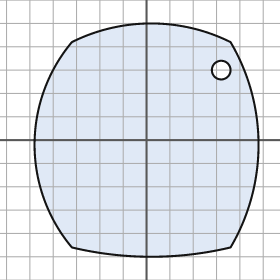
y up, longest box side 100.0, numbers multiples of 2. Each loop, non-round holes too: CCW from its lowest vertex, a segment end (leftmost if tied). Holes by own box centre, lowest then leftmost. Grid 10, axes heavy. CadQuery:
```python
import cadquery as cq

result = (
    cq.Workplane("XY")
    .moveTo(-32.0, -46.0)
    .threePointArc((2.0, -50.0), (36.0, -46.0))
    .threePointArc((48.0, -2.0), (36.0, 42.0))
    .threePointArc((2.0, 50.0), (-32.0, 42.0))
    .threePointArc((-48.0, -2.0), (-32.0, -46.0))
    .close()
    .moveTo(32.0, 30.0)
    .circle(4.0)
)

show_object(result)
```